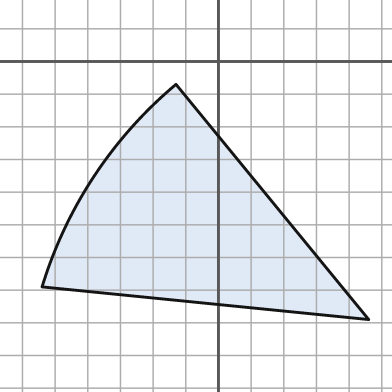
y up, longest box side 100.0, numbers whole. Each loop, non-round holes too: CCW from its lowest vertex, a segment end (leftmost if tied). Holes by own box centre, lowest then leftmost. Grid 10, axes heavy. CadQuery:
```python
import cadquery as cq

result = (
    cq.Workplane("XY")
    .moveTo(46.0, -79.0)
    .lineTo(-13.0, -7.0)
    .threePointArc((-38.0, -35.0), (-54.0, -69.0))
    .close()
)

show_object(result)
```